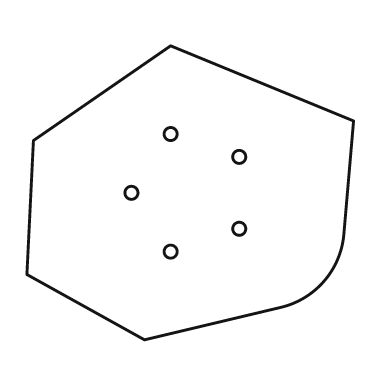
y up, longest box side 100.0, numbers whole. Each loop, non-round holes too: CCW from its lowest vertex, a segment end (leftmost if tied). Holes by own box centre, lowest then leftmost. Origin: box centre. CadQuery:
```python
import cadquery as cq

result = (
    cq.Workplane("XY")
    .moveTo(-14.0, -45.0)
    .lineTo(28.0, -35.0)
    .threePointArc((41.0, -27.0), (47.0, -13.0))
    .lineTo(50.0, 22.0)
    .lineTo(-6.0, 45.0)
    .lineTo(-48.0, 16.0)
    .lineTo(-50.0, -25.0)
    .close()
    .moveTo(-6.0, -18.0)
    .circle(2.0)
    .moveTo(15.0, -11.0)
    .circle(2.0)
    .moveTo(-18.0, 0.0)
    .circle(2.0)
    .moveTo(15.0, 11.0)
    .circle(2.0)
    .moveTo(-6.0, 18.0)
    .circle(2.0)
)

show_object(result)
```